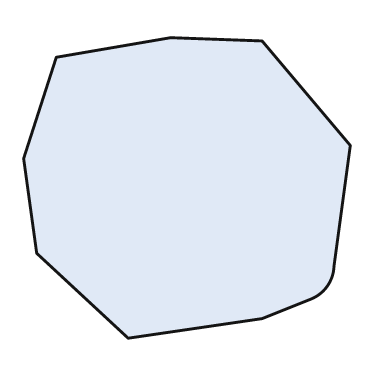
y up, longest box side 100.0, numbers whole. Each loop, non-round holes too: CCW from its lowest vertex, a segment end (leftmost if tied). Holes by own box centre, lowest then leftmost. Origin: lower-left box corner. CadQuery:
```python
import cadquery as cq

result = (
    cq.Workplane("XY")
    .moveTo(32.0, 0.0)
    .lineTo(73.0, 6.0)
    .lineTo(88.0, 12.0)
    .threePointArc((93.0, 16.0), (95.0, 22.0))
    .lineTo(100.0, 59.0)
    .lineTo(73.0, 91.0)
    .lineTo(45.0, 92.0)
    .lineTo(10.0, 86.0)
    .lineTo(0.0, 55.0)
    .lineTo(4.0, 26.0)
    .close()
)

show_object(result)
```